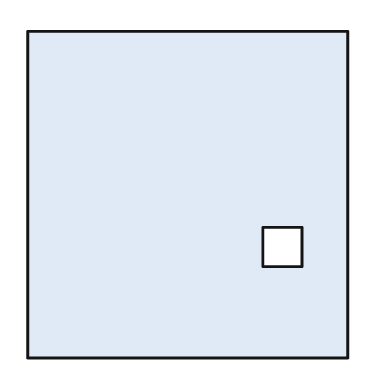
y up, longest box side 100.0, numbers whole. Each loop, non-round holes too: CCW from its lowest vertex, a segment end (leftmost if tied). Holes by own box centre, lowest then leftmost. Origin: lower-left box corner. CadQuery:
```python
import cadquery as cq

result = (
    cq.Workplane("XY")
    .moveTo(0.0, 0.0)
    .lineTo(98.0, 0.0)
    .lineTo(98.0, 100.0)
    .lineTo(0.0, 100.0)
    .close()
    .moveTo(72.0, 28.0)
    .lineTo(84.0, 28.0)
    .lineTo(84.0, 40.0)
    .lineTo(72.0, 40.0)
    .close()
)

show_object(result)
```